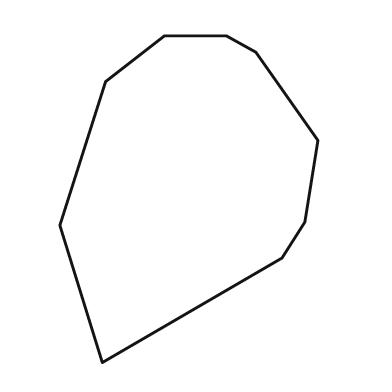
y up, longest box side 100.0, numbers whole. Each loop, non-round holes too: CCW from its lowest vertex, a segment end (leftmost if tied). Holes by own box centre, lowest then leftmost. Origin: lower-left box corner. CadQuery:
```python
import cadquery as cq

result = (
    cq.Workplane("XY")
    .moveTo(13.0, 0.0)
    .lineTo(68.0, 32.0)
    .lineTo(75.0, 43.0)
    .lineTo(79.0, 68.0)
    .lineTo(60.0, 95.0)
    .lineTo(51.0, 100.0)
    .lineTo(32.0, 100.0)
    .lineTo(14.0, 86.0)
    .lineTo(0.0, 42.0)
    .close()
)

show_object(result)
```